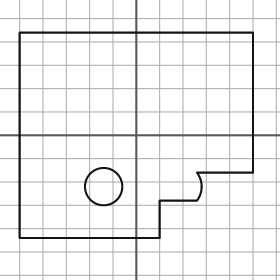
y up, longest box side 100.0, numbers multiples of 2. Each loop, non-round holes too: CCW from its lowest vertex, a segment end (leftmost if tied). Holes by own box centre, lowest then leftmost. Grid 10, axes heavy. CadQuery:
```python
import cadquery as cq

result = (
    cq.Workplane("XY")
    .moveTo(-50.0, -44.0)
    .lineTo(10.0, -44.0)
    .lineTo(10.0, -28.0)
    .lineTo(26.0, -28.0)
    .threePointArc((28.0, -22.0), (26.0, -16.0))
    .lineTo(50.0, -16.0)
    .lineTo(50.0, 44.0)
    .lineTo(-50.0, 44.0)
    .close()
    .moveTo(-14.0, -22.0)
    .circle(8.0)
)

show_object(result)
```